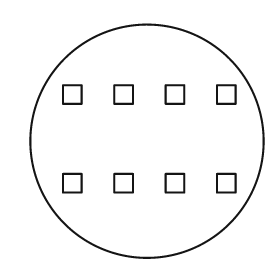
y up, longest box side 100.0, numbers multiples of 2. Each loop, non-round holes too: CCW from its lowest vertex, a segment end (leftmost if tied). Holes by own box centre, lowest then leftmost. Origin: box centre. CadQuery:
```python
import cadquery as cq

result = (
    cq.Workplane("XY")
    .moveTo(0.0, 0.0)
    .circle(50.0)
    .moveTo(-36.0, -22.0)
    .lineTo(-28.0, -22.0)
    .lineTo(-28.0, -14.0)
    .lineTo(-36.0, -14.0)
    .close()
    .moveTo(-14.0, -22.0)
    .lineTo(-6.0, -22.0)
    .lineTo(-6.0, -14.0)
    .lineTo(-14.0, -14.0)
    .close()
    .moveTo(8.0, -22.0)
    .lineTo(16.0, -22.0)
    .lineTo(16.0, -14.0)
    .lineTo(8.0, -14.0)
    .close()
    .moveTo(30.0, -22.0)
    .lineTo(38.0, -22.0)
    .lineTo(38.0, -14.0)
    .lineTo(30.0, -14.0)
    .close()
    .moveTo(-36.0, 16.0)
    .lineTo(-28.0, 16.0)
    .lineTo(-28.0, 24.0)
    .lineTo(-36.0, 24.0)
    .close()
    .moveTo(-14.0, 16.0)
    .lineTo(-6.0, 16.0)
    .lineTo(-6.0, 24.0)
    .lineTo(-14.0, 24.0)
    .close()
    .moveTo(8.0, 16.0)
    .lineTo(16.0, 16.0)
    .lineTo(16.0, 24.0)
    .lineTo(8.0, 24.0)
    .close()
    .moveTo(30.0, 16.0)
    .lineTo(38.0, 16.0)
    .lineTo(38.0, 24.0)
    .lineTo(30.0, 24.0)
    .close()
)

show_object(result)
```